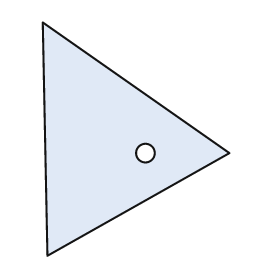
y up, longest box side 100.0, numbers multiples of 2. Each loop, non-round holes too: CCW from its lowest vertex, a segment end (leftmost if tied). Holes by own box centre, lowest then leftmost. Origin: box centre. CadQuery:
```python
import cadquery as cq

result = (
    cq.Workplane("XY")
    .moveTo(-38.0, -50.0)
    .lineTo(40.0, -6.0)
    .lineTo(-40.0, 50.0)
    .close()
    .moveTo(4.0, -6.0)
    .circle(4.0)
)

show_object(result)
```